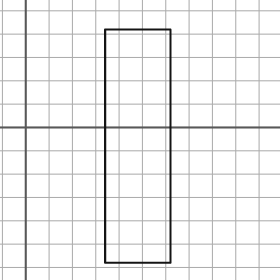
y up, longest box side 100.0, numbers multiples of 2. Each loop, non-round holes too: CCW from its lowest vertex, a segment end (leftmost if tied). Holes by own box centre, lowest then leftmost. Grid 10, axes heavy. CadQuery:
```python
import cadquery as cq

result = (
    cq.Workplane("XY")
    .moveTo(34.0, -58.0)
    .lineTo(62.0, -58.0)
    .lineTo(62.0, 42.0)
    .lineTo(34.0, 42.0)
    .close()
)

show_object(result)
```